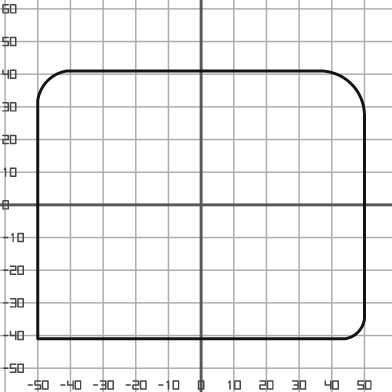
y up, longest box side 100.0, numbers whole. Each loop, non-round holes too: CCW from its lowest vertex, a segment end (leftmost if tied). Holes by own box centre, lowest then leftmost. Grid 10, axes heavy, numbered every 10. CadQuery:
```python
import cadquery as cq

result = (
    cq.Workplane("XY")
    .moveTo(-50.0, -41.0)
    .lineTo(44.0, -41.0)
    .threePointArc((48.0, -39.0), (50.0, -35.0))
    .lineTo(50.0, 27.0)
    .threePointArc((46.0, 37.0), (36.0, 41.0))
    .lineTo(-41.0, 41.0)
    .threePointArc((-47.0, 38.0), (-50.0, 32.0))
    .close()
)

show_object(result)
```